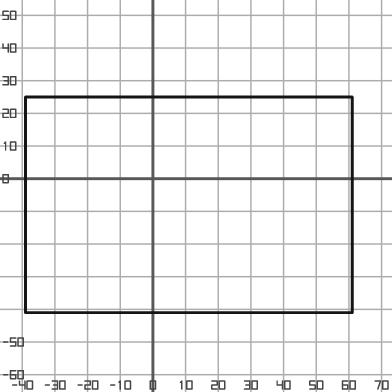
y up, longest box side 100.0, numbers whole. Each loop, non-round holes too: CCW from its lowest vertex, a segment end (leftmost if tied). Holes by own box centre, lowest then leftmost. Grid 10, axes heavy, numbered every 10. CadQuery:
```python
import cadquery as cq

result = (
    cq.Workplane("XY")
    .moveTo(-39.0, -41.0)
    .lineTo(61.0, -41.0)
    .lineTo(61.0, 25.0)
    .lineTo(-39.0, 25.0)
    .close()
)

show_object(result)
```